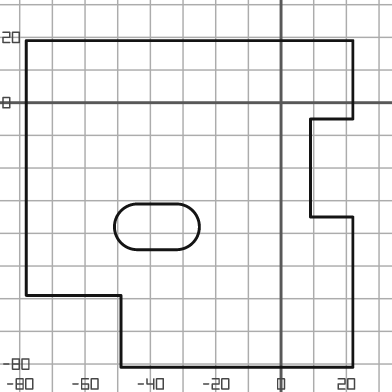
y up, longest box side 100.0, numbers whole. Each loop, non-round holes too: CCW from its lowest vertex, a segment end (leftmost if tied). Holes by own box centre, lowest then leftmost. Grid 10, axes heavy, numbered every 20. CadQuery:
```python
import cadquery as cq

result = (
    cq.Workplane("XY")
    .moveTo(-49.0, -81.0)
    .lineTo(22.0, -81.0)
    .lineTo(22.0, -35.0)
    .lineTo(9.0, -35.0)
    .lineTo(9.0, -5.0)
    .lineTo(22.0, -5.0)
    .lineTo(22.0, 19.0)
    .lineTo(-78.0, 19.0)
    .lineTo(-78.0, -59.0)
    .lineTo(-49.0, -59.0)
    .close()
    .moveTo(-44.0, -45.0)
    .lineTo(-32.0, -45.0)
    .threePointArc((-25.0, -38.0), (-32.0, -31.0))
    .lineTo(-44.0, -31.0)
    .threePointArc((-51.0, -38.0), (-44.0, -45.0))
    .close()
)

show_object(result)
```